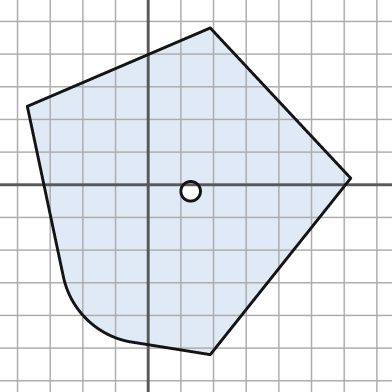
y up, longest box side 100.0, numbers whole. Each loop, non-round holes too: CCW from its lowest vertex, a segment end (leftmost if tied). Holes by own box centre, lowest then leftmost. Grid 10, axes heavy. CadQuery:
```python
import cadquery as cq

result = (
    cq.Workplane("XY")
    .moveTo(19.0, -52.0)
    .lineTo(62.0, 2.0)
    .lineTo(19.0, 48.0)
    .lineTo(-37.0, 24.0)
    .lineTo(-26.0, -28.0)
    .threePointArc((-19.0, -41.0), (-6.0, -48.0))
    .close()
    .moveTo(13.0, -2.0)
    .circle(3.0)
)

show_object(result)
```